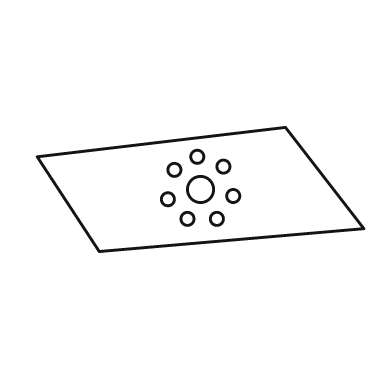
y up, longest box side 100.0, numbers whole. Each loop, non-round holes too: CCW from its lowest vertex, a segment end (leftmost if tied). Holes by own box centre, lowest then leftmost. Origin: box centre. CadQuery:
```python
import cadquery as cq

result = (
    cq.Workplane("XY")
    .moveTo(-31.0, -19.0)
    .lineTo(50.0, -12.0)
    .lineTo(26.0, 19.0)
    .lineTo(-50.0, 10.0)
    .close()
    .moveTo(-4.0, -9.0)
    .circle(2.0)
    .moveTo(5.0, -9.0)
    .circle(2.0)
    .moveTo(-10.0, -3.0)
    .circle(2.0)
    .moveTo(10.0, -2.0)
    .circle(2.0)
    .moveTo(0.0, 0.0)
    .circle(4.0)
    .moveTo(-8.0, 6.0)
    .circle(2.0)
    .moveTo(7.0, 7.0)
    .circle(2.0)
    .moveTo(-1.0, 10.0)
    .circle(2.0)
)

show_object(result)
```